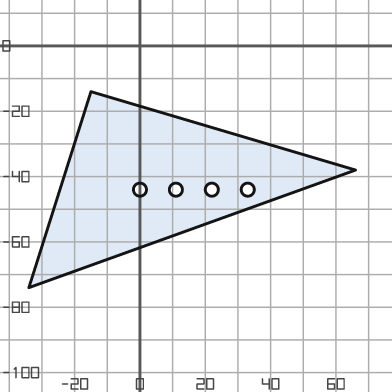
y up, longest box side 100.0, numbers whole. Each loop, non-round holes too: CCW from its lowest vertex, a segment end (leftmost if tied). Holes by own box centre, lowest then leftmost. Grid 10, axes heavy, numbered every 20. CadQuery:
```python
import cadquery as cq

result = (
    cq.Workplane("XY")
    .moveTo(-34.0, -74.0)
    .lineTo(66.0, -38.0)
    .lineTo(-15.0, -14.0)
    .close()
    .moveTo(0.0, -44.0)
    .circle(2.0)
    .moveTo(11.0, -44.0)
    .circle(2.0)
    .moveTo(22.0, -44.0)
    .circle(2.0)
    .moveTo(33.0, -44.0)
    .circle(2.0)
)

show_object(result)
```